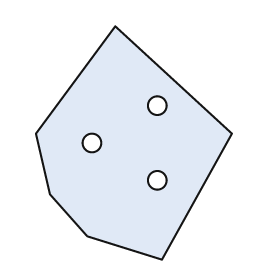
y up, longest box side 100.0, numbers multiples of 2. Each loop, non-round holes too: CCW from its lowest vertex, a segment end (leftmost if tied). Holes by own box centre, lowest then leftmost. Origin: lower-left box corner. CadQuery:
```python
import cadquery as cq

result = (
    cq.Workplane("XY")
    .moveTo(54.0, 0.0)
    .lineTo(84.0, 54.0)
    .lineTo(34.0, 100.0)
    .lineTo(0.0, 54.0)
    .lineTo(6.0, 28.0)
    .lineTo(22.0, 10.0)
    .close()
    .moveTo(52.0, 34.0)
    .circle(4.0)
    .moveTo(24.0, 50.0)
    .circle(4.0)
    .moveTo(52.0, 66.0)
    .circle(4.0)
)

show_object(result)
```